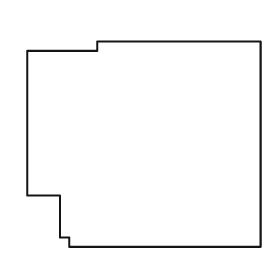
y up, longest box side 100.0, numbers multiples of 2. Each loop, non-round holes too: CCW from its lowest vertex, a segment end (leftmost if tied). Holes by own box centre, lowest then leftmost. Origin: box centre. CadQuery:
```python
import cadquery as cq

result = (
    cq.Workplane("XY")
    .moveTo(-32.0, -44.0)
    .lineTo(50.0, -44.0)
    .lineTo(50.0, 44.0)
    .lineTo(-20.0, 44.0)
    .lineTo(-20.0, 40.0)
    .lineTo(-50.0, 40.0)
    .lineTo(-50.0, -22.0)
    .lineTo(-36.0, -22.0)
    .lineTo(-36.0, -40.0)
    .lineTo(-32.0, -40.0)
    .close()
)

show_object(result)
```